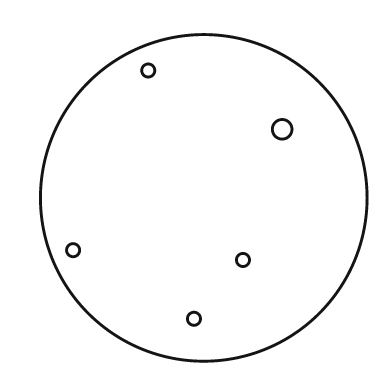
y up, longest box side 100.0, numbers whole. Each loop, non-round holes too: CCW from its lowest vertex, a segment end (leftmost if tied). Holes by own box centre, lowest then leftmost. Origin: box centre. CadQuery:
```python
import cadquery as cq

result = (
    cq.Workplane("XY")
    .moveTo(0.0, 0.0)
    .circle(50.0)
    .moveTo(-3.0, -37.0)
    .circle(2.0)
    .moveTo(12.0, -19.0)
    .circle(2.0)
    .moveTo(-40.0, -16.0)
    .circle(2.0)
    .moveTo(24.0, 21.0)
    .circle(3.0)
    .moveTo(-17.0, 39.0)
    .circle(2.0)
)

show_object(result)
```